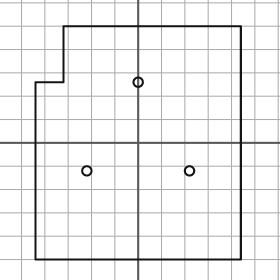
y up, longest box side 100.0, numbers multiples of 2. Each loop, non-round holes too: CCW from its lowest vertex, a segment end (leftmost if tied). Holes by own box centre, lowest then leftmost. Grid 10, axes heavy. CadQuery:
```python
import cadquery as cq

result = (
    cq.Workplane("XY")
    .moveTo(-44.0, -50.0)
    .lineTo(44.0, -50.0)
    .lineTo(44.0, 50.0)
    .lineTo(-32.0, 50.0)
    .lineTo(-32.0, 26.0)
    .lineTo(-44.0, 26.0)
    .close()
    .moveTo(-22.0, -12.0)
    .circle(2.0)
    .moveTo(22.0, -12.0)
    .circle(2.0)
    .moveTo(0.0, 26.0)
    .circle(2.0)
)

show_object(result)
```